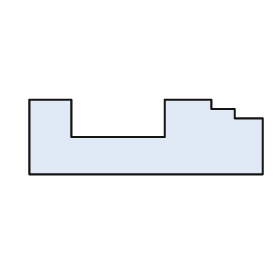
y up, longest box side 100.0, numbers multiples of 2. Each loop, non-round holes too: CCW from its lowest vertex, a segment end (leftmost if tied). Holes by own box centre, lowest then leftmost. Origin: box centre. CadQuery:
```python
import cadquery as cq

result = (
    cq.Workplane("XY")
    .moveTo(-50.0, -16.0)
    .lineTo(50.0, -16.0)
    .lineTo(50.0, 8.0)
    .lineTo(38.0, 8.0)
    .lineTo(38.0, 12.0)
    .lineTo(28.0, 12.0)
    .lineTo(28.0, 16.0)
    .lineTo(8.0, 16.0)
    .lineTo(8.0, 0.0)
    .lineTo(-32.0, 0.0)
    .lineTo(-32.0, 16.0)
    .lineTo(-50.0, 16.0)
    .close()
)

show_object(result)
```